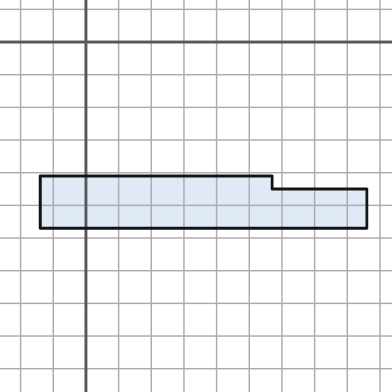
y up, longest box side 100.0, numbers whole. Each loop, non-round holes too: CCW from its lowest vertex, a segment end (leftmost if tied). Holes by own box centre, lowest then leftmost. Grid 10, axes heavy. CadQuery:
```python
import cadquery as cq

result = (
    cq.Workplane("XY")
    .moveTo(-14.0, -57.0)
    .lineTo(86.0, -57.0)
    .lineTo(86.0, -45.0)
    .lineTo(57.0, -45.0)
    .lineTo(57.0, -41.0)
    .lineTo(-14.0, -41.0)
    .close()
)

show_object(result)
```